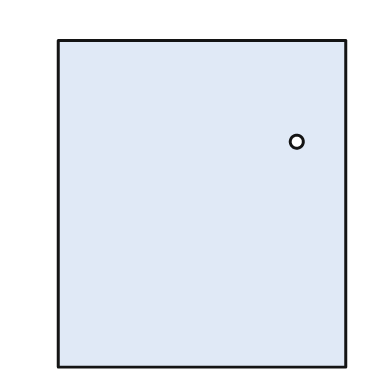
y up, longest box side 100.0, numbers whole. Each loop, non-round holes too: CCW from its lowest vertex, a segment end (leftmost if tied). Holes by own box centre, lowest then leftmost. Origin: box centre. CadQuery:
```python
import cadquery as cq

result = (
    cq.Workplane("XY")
    .moveTo(-44.0, -50.0)
    .lineTo(44.0, -50.0)
    .lineTo(44.0, 50.0)
    .lineTo(-44.0, 50.0)
    .close()
    .moveTo(29.0, 19.0)
    .circle(2.0)
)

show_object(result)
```